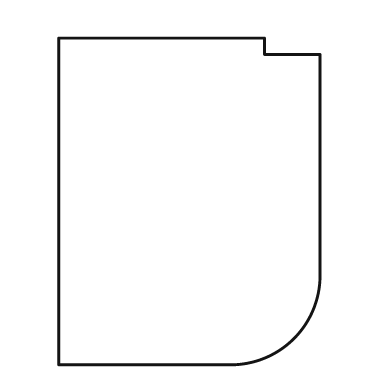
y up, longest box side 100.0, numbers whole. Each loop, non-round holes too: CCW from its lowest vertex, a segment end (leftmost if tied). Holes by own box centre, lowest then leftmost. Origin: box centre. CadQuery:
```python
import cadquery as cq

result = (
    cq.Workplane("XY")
    .moveTo(-40.0, -50.0)
    .lineTo(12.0, -50.0)
    .threePointArc((32.0, -42.0), (40.0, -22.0))
    .lineTo(40.0, 45.0)
    .lineTo(23.0, 45.0)
    .lineTo(23.0, 50.0)
    .lineTo(-40.0, 50.0)
    .close()
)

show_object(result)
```